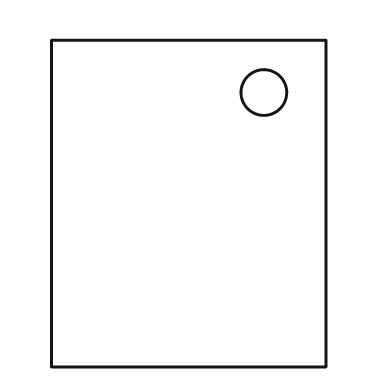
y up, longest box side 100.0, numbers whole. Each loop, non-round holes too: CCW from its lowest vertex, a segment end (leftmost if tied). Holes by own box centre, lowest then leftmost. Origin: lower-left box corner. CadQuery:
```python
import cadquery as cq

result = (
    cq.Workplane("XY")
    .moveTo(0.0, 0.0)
    .lineTo(84.0, 0.0)
    .lineTo(84.0, 100.0)
    .lineTo(0.0, 100.0)
    .close()
    .moveTo(65.0, 84.0)
    .circle(7.0)
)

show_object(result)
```